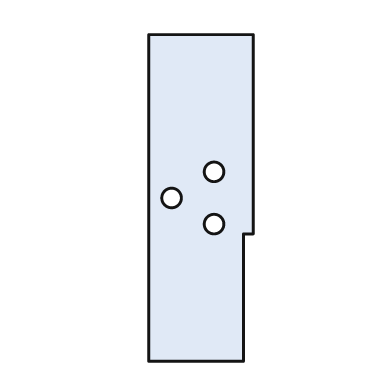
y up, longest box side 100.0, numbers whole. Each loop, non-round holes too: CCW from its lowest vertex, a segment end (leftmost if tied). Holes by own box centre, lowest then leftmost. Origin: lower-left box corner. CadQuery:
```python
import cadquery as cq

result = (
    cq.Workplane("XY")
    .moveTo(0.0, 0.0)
    .lineTo(29.0, 0.0)
    .lineTo(29.0, 39.0)
    .lineTo(32.0, 39.0)
    .lineTo(32.0, 100.0)
    .lineTo(0.0, 100.0)
    .close()
    .moveTo(20.0, 42.0)
    .circle(3.0)
    .moveTo(7.0, 50.0)
    .circle(3.0)
    .moveTo(20.0, 58.0)
    .circle(3.0)
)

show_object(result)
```